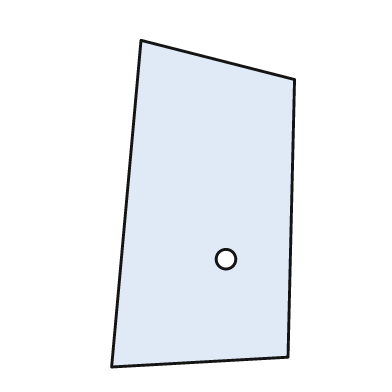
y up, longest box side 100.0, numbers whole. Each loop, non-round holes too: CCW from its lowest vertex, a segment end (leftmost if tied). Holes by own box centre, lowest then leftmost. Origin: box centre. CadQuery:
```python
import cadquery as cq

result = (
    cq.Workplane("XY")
    .moveTo(-28.0, -50.0)
    .lineTo(26.0, -47.0)
    .lineTo(28.0, 38.0)
    .lineTo(-19.0, 50.0)
    .close()
    .moveTo(7.0, -17.0)
    .circle(3.0)
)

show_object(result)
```